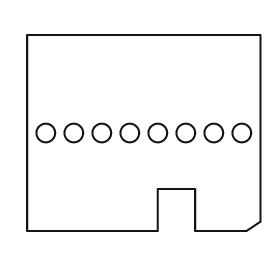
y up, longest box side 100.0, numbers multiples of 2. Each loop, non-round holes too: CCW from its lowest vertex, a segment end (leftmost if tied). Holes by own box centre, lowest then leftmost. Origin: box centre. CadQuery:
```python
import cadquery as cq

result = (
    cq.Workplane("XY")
    .moveTo(-50.0, -42.0)
    .lineTo(6.0, -42.0)
    .lineTo(6.0, -24.0)
    .lineTo(22.0, -24.0)
    .lineTo(22.0, -42.0)
    .lineTo(44.0, -42.0)
    .lineTo(50.0, -38.0)
    .lineTo(50.0, 42.0)
    .lineTo(-50.0, 42.0)
    .close()
    .moveTo(-42.0, 0.0)
    .circle(4.0)
    .moveTo(-30.0, 0.0)
    .circle(4.0)
    .moveTo(-18.0, 0.0)
    .circle(4.0)
    .moveTo(-6.0, 0.0)
    .circle(4.0)
    .moveTo(6.0, 0.0)
    .circle(4.0)
    .moveTo(18.0, 0.0)
    .circle(4.0)
    .moveTo(30.0, 0.0)
    .circle(4.0)
    .moveTo(42.0, 0.0)
    .circle(4.0)
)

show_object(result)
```